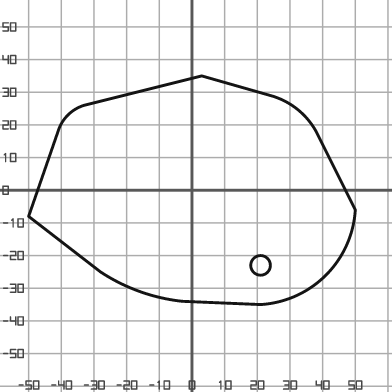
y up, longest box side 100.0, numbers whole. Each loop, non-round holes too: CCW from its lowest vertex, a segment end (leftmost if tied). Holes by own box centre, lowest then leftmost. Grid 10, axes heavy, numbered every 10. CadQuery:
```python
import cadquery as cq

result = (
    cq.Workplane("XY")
    .moveTo(21.0, -35.0)
    .threePointArc((41.0, -26.0), (50.0, -6.0))
    .lineTo(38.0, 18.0)
    .threePointArc((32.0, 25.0), (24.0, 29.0))
    .lineTo(3.0, 35.0)
    .lineTo(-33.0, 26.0)
    .threePointArc((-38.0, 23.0), (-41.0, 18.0))
    .lineTo(-50.0, -8.0)
    .lineTo(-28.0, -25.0)
    .threePointArc((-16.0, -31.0), (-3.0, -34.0))
    .close()
    .moveTo(21.0, -23.0)
    .circle(3.0)
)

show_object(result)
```